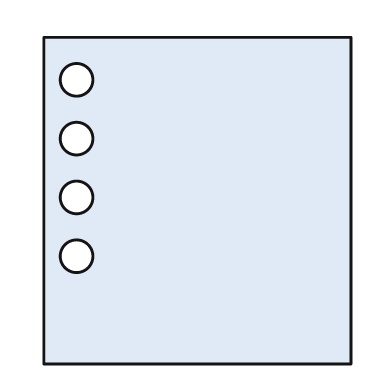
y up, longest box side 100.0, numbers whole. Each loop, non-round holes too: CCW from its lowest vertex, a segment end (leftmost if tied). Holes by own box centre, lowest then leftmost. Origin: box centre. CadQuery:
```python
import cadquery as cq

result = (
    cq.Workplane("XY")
    .moveTo(-47.0, -50.0)
    .lineTo(47.0, -50.0)
    .lineTo(47.0, 50.0)
    .lineTo(-47.0, 50.0)
    .close()
    .moveTo(-37.0, -17.0)
    .circle(5.0)
    .moveTo(-37.0, 1.0)
    .circle(5.0)
    .moveTo(-37.0, 19.0)
    .circle(5.0)
    .moveTo(-37.0, 37.0)
    .circle(5.0)
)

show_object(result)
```